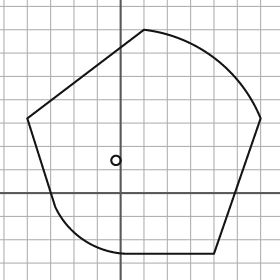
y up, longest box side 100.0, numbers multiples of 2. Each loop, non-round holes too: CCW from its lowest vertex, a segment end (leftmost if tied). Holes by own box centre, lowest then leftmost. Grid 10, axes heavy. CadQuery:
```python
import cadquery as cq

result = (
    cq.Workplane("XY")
    .moveTo(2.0, -26.0)
    .lineTo(40.0, -26.0)
    .lineTo(60.0, 32.0)
    .threePointArc((40.0, 58.0), (10.0, 70.0))
    .lineTo(-40.0, 32.0)
    .lineTo(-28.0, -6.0)
    .threePointArc((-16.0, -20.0), (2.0, -26.0))
    .close()
    .moveTo(-2.0, 14.0)
    .circle(2.0)
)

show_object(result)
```